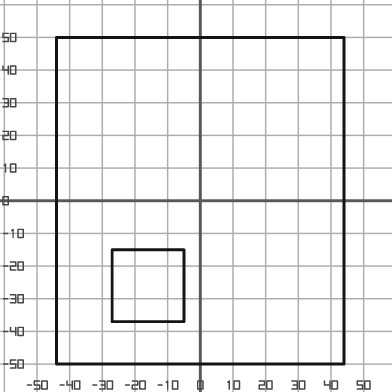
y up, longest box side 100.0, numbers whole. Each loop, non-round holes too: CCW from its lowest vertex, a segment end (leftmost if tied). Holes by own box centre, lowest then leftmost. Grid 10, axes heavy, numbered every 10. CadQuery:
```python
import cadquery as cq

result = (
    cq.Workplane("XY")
    .moveTo(-44.0, -50.0)
    .lineTo(44.0, -50.0)
    .lineTo(44.0, 50.0)
    .lineTo(-44.0, 50.0)
    .close()
    .moveTo(-27.0, -37.0)
    .lineTo(-5.0, -37.0)
    .lineTo(-5.0, -15.0)
    .lineTo(-27.0, -15.0)
    .close()
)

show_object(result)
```